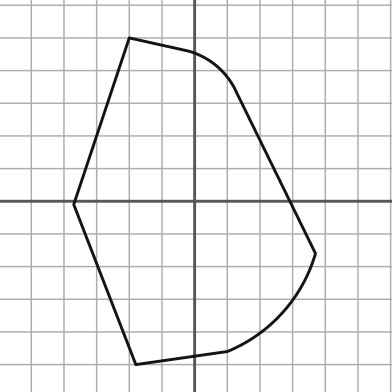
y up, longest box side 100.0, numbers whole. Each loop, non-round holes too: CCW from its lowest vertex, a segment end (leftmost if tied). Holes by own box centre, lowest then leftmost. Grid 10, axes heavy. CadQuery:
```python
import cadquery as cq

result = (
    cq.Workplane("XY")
    .moveTo(-18.0, -50.0)
    .lineTo(10.0, -46.0)
    .threePointArc((27.0, -34.0), (37.0, -16.0))
    .lineTo(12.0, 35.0)
    .threePointArc((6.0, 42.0), (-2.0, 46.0))
    .lineTo(-20.0, 50.0)
    .lineTo(-37.0, -1.0)
    .close()
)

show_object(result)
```